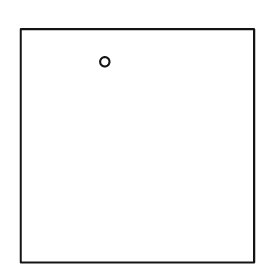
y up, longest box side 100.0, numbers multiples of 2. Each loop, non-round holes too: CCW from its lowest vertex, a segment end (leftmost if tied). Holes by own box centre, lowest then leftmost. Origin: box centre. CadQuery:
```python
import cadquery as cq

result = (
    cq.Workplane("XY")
    .moveTo(-50.0, -50.0)
    .lineTo(50.0, -50.0)
    .lineTo(50.0, 50.0)
    .lineTo(-50.0, 50.0)
    .close()
    .moveTo(-14.0, 36.0)
    .circle(2.0)
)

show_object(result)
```